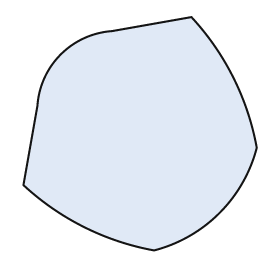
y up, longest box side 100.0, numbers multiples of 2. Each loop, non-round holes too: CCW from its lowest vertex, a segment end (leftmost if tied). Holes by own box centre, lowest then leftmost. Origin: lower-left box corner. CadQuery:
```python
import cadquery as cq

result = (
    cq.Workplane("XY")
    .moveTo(56.0, 0.0)
    .threePointArc((84.0, 16.0), (100.0, 44.0))
    .threePointArc((90.0, 74.0), (72.0, 100.0))
    .lineTo(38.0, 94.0)
    .threePointArc((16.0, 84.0), (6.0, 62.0))
    .lineTo(0.0, 28.0)
    .threePointArc((26.0, 10.0), (56.0, 0.0))
    .close()
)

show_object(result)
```